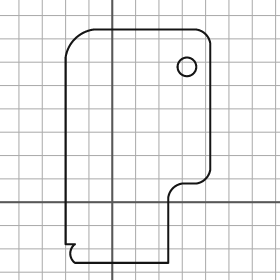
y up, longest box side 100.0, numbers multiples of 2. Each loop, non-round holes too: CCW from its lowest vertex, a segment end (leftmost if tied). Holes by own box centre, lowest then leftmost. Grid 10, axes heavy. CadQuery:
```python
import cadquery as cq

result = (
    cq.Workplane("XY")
    .moveTo(-16.0, -26.0)
    .lineTo(24.0, -26.0)
    .lineTo(24.0, 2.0)
    .threePointArc((26.0, 6.0), (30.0, 8.0))
    .lineTo(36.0, 8.0)
    .threePointArc((40.0, 10.0), (42.0, 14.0))
    .lineTo(42.0, 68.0)
    .threePointArc((40.0, 72.0), (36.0, 74.0))
    .lineTo(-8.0, 74.0)
    .threePointArc((-16.0, 70.0), (-20.0, 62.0))
    .lineTo(-20.0, -18.0)
    .lineTo(-16.0, -18.0)
    .threePointArc((-18.0, -22.0), (-16.0, -26.0))
    .close()
    .moveTo(32.0, 58.0)
    .circle(4.0)
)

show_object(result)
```